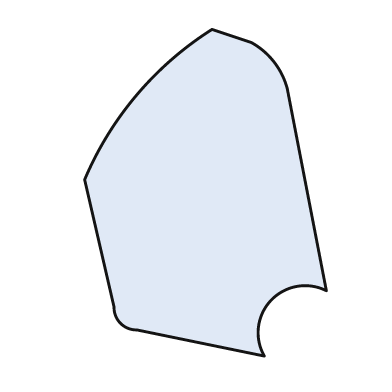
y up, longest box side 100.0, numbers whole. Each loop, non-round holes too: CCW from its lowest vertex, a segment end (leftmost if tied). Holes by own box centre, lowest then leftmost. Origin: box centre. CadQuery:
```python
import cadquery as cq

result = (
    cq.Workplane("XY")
    .moveTo(18.0, -50.0)
    .threePointArc((20.0, -33.0), (37.0, -30.0))
    .lineTo(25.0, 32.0)
    .threePointArc((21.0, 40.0), (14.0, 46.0))
    .lineTo(2.0, 50.0)
    .threePointArc((-21.0, 30.0), (-37.0, 4.0))
    .lineTo(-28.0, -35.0)
    .threePointArc((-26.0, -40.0), (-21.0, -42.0))
    .close()
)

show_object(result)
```